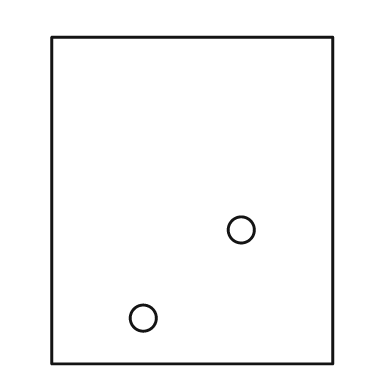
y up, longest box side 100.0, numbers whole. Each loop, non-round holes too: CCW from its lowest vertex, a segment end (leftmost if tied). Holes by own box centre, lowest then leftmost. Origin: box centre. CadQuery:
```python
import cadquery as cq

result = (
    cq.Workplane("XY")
    .moveTo(-43.0, -50.0)
    .lineTo(43.0, -50.0)
    .lineTo(43.0, 50.0)
    .lineTo(-43.0, 50.0)
    .close()
    .moveTo(-15.0, -36.0)
    .circle(4.0)
    .moveTo(15.0, -9.0)
    .circle(4.0)
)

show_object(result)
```